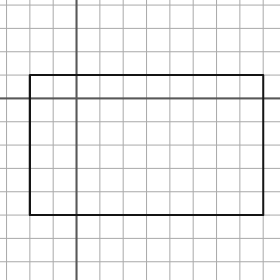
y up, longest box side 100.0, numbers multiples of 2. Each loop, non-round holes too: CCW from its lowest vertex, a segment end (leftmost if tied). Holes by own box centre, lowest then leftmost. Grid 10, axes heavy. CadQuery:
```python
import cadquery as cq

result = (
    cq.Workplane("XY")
    .moveTo(-20.0, -50.0)
    .lineTo(80.0, -50.0)
    .lineTo(80.0, 10.0)
    .lineTo(-20.0, 10.0)
    .close()
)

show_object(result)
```